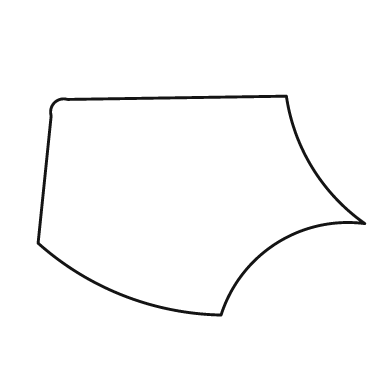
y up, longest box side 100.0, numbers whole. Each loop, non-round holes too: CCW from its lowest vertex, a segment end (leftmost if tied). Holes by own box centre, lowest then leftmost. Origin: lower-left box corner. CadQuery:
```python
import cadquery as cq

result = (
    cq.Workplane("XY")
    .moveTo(56.0, 0.0)
    .threePointArc((73.0, 22.0), (100.0, 28.0))
    .threePointArc((84.0, 45.0), (76.0, 67.0))
    .lineTo(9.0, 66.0)
    .threePointArc((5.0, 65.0), (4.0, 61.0))
    .lineTo(0.0, 22.0)
    .threePointArc((26.0, 6.0), (56.0, 0.0))
    .close()
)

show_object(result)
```